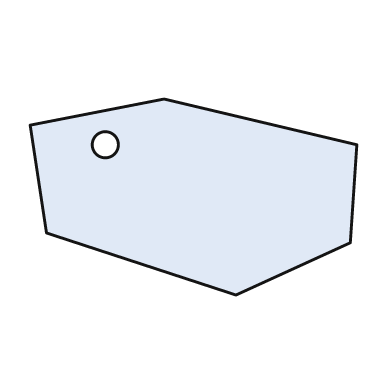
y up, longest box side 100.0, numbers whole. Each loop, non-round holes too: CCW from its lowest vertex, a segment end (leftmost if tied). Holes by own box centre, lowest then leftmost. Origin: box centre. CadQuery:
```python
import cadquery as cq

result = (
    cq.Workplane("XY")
    .moveTo(13.0, -30.0)
    .lineTo(48.0, -14.0)
    .lineTo(50.0, 16.0)
    .lineTo(-9.0, 30.0)
    .lineTo(-50.0, 22.0)
    .lineTo(-45.0, -11.0)
    .close()
    .moveTo(-27.0, 16.0)
    .circle(4.0)
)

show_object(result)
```